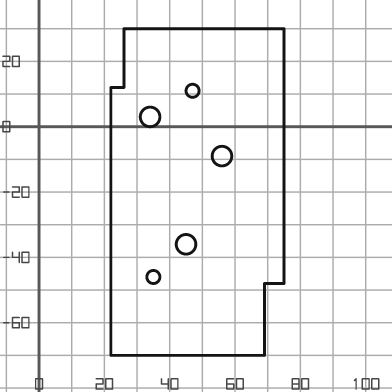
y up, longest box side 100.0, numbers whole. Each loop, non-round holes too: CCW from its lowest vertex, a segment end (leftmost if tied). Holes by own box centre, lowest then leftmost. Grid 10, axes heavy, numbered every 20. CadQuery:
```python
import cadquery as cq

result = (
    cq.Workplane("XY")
    .moveTo(22.0, -70.0)
    .lineTo(69.0, -70.0)
    .lineTo(69.0, -48.0)
    .lineTo(75.0, -48.0)
    .lineTo(75.0, 30.0)
    .lineTo(26.0, 30.0)
    .lineTo(26.0, 12.0)
    .lineTo(22.0, 12.0)
    .close()
    .moveTo(35.0, -46.0)
    .circle(2.0)
    .moveTo(45.0, -36.0)
    .circle(3.0)
    .moveTo(56.0, -9.0)
    .circle(3.0)
    .moveTo(34.0, 3.0)
    .circle(3.0)
    .moveTo(47.0, 11.0)
    .circle(2.0)
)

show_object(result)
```